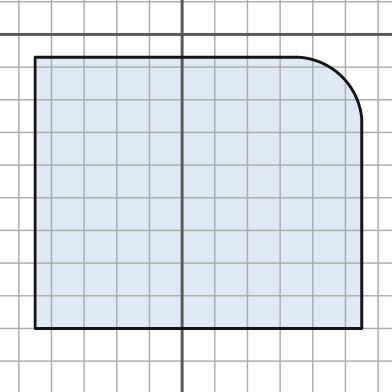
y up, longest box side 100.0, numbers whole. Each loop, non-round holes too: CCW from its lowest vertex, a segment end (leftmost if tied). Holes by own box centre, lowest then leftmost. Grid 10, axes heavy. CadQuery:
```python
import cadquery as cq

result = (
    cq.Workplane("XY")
    .moveTo(-45.0, -90.0)
    .lineTo(55.0, -90.0)
    .lineTo(55.0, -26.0)
    .threePointArc((49.0, -13.0), (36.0, -7.0))
    .lineTo(-45.0, -7.0)
    .close()
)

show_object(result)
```